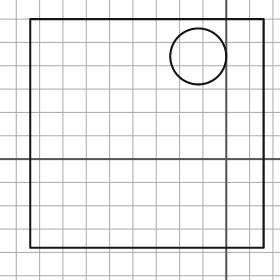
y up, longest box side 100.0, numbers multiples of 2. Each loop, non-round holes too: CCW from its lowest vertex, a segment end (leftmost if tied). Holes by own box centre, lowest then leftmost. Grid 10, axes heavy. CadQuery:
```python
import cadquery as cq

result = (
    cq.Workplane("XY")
    .moveTo(-84.0, -38.0)
    .lineTo(16.0, -38.0)
    .lineTo(16.0, 60.0)
    .lineTo(-84.0, 60.0)
    .close()
    .moveTo(-12.0, 44.0)
    .circle(12.0)
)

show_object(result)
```